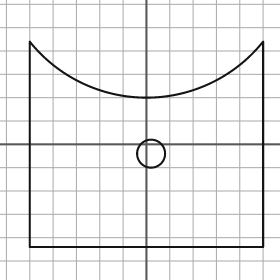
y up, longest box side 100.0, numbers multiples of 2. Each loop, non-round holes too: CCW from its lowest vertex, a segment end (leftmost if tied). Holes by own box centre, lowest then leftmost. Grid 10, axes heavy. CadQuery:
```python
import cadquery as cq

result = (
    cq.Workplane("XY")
    .moveTo(-50.0, -44.0)
    .lineTo(50.0, -44.0)
    .lineTo(50.0, 44.0)
    .threePointArc((0.0, 20.0), (-50.0, 44.0))
    .close()
    .moveTo(2.0, -4.0)
    .circle(6.0)
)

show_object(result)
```